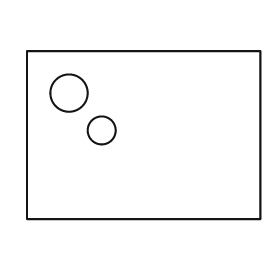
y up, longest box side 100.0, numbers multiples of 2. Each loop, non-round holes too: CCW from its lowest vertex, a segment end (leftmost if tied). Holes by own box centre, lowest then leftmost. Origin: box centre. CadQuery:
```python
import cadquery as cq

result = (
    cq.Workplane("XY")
    .moveTo(-50.0, -36.0)
    .lineTo(50.0, -36.0)
    .lineTo(50.0, 36.0)
    .lineTo(-50.0, 36.0)
    .close()
    .moveTo(-18.0, 2.0)
    .circle(6.0)
    .moveTo(-32.0, 18.0)
    .circle(8.0)
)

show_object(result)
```